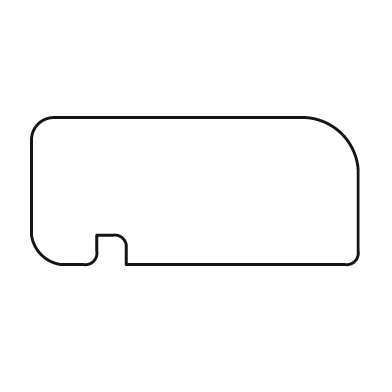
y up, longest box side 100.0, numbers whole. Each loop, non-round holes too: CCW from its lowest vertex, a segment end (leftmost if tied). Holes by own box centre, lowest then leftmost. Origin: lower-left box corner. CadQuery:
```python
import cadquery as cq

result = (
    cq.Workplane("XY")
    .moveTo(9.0, 0.0)
    .lineTo(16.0, 0.0)
    .threePointArc((19.0, 1.0), (20.0, 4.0))
    .lineTo(20.0, 9.0)
    .lineTo(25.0, 9.0)
    .threePointArc((28.0, 8.0), (29.0, 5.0))
    .lineTo(29.0, 0.0)
    .lineTo(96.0, 0.0)
    .threePointArc((99.0, 1.0), (100.0, 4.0))
    .lineTo(100.0, 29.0)
    .threePointArc((95.0, 40.0), (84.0, 45.0))
    .lineTo(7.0, 45.0)
    .threePointArc((2.0, 43.0), (0.0, 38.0))
    .lineTo(0.0, 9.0)
    .threePointArc((3.0, 3.0), (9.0, 0.0))
    .close()
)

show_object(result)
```